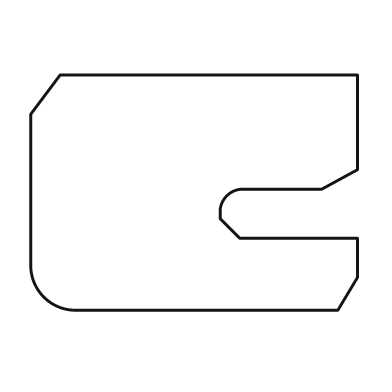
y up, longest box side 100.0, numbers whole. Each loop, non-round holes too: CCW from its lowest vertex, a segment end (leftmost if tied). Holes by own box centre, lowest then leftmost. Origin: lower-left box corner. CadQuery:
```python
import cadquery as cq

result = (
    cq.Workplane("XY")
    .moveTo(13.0, 0.0)
    .lineTo(94.0, 0.0)
    .lineTo(100.0, 10.0)
    .lineTo(100.0, 22.0)
    .lineTo(64.0, 22.0)
    .lineTo(58.0, 28.0)
    .lineTo(58.0, 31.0)
    .threePointArc((60.0, 35.0), (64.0, 37.0))
    .lineTo(89.0, 37.0)
    .lineTo(100.0, 43.0)
    .lineTo(100.0, 72.0)
    .lineTo(9.0, 72.0)
    .lineTo(0.0, 60.0)
    .lineTo(0.0, 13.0)
    .threePointArc((4.0, 4.0), (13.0, 0.0))
    .close()
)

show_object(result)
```